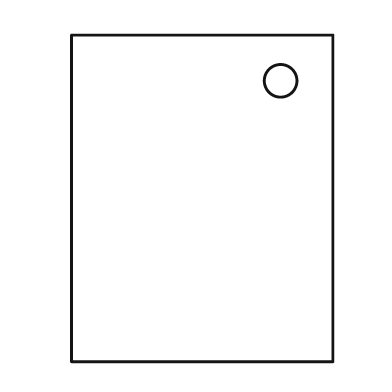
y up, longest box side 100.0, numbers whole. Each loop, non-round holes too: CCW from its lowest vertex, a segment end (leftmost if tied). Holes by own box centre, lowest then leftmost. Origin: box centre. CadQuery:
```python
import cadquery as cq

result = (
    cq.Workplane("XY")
    .moveTo(-40.0, -50.0)
    .lineTo(40.0, -50.0)
    .lineTo(40.0, 50.0)
    .lineTo(-40.0, 50.0)
    .close()
    .moveTo(24.0, 36.0)
    .circle(5.0)
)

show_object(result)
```